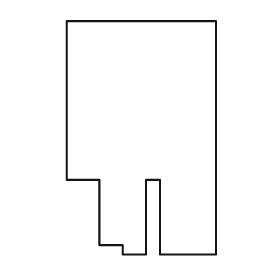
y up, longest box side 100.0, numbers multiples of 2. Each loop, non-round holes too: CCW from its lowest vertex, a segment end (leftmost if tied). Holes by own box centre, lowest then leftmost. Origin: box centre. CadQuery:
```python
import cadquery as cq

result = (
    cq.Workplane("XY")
    .moveTo(-8.0, -50.0)
    .lineTo(2.0, -50.0)
    .lineTo(2.0, -18.0)
    .lineTo(8.0, -18.0)
    .lineTo(8.0, -50.0)
    .lineTo(32.0, -50.0)
    .lineTo(32.0, 50.0)
    .lineTo(-32.0, 50.0)
    .lineTo(-32.0, -18.0)
    .lineTo(-18.0, -18.0)
    .lineTo(-18.0, -46.0)
    .lineTo(-8.0, -46.0)
    .close()
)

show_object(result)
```